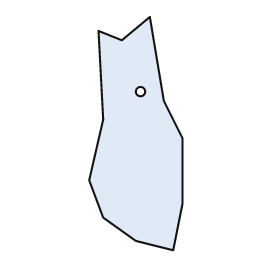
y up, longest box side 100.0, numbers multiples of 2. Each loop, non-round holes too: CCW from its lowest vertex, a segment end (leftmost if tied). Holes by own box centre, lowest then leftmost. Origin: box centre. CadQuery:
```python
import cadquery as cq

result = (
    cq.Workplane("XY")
    .moveTo(16.0, -50.0)
    .lineTo(20.0, -30.0)
    .lineTo(20.0, -2.0)
    .lineTo(12.0, 14.0)
    .lineTo(6.0, 50.0)
    .lineTo(-6.0, 40.0)
    .lineTo(-16.0, 44.0)
    .lineTo(-14.0, 6.0)
    .lineTo(-20.0, -20.0)
    .lineTo(-14.0, -36.0)
    .lineTo(0.0, -46.0)
    .close()
    .moveTo(2.0, 18.0)
    .circle(2.0)
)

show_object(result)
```